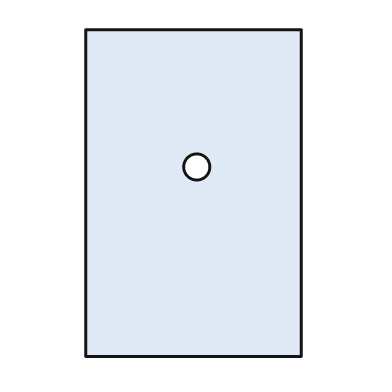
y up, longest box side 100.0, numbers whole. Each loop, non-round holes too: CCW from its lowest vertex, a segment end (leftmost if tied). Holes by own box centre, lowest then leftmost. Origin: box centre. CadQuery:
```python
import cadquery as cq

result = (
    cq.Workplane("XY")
    .moveTo(-33.0, -50.0)
    .lineTo(33.0, -50.0)
    .lineTo(33.0, 50.0)
    .lineTo(-33.0, 50.0)
    .close()
    .moveTo(1.0, 8.0)
    .circle(4.0)
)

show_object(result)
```